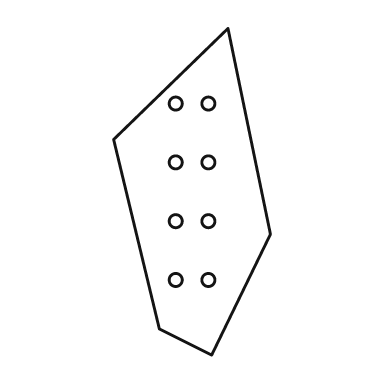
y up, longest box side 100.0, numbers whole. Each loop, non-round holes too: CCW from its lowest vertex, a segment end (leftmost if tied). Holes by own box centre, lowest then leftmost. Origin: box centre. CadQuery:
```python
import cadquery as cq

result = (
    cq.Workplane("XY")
    .moveTo(6.0, -50.0)
    .lineTo(24.0, -13.0)
    .lineTo(11.0, 50.0)
    .lineTo(-24.0, 16.0)
    .lineTo(-10.0, -42.0)
    .close()
    .moveTo(-5.0, -27.0)
    .circle(2.0)
    .moveTo(5.0, -27.0)
    .circle(2.0)
    .moveTo(-5.0, -9.0)
    .circle(2.0)
    .moveTo(5.0, -9.0)
    .circle(2.0)
    .moveTo(-5.0, 9.0)
    .circle(2.0)
    .moveTo(5.0, 9.0)
    .circle(2.0)
    .moveTo(-5.0, 27.0)
    .circle(2.0)
    .moveTo(5.0, 27.0)
    .circle(2.0)
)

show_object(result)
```